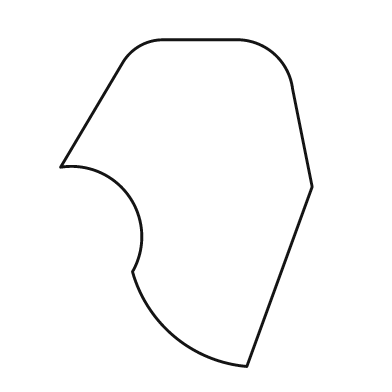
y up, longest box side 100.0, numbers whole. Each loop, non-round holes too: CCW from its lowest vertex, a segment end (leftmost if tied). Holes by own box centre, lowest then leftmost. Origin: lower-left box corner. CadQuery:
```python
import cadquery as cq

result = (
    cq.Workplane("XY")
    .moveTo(57.0, 0.0)
    .lineTo(77.0, 55.0)
    .lineTo(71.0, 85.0)
    .threePointArc((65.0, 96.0), (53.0, 100.0))
    .lineTo(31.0, 100.0)
    .threePointArc((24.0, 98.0), (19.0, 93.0))
    .lineTo(0.0, 61.0)
    .threePointArc((21.0, 52.0), (22.0, 29.0))
    .threePointArc((35.0, 9.0), (57.0, 0.0))
    .close()
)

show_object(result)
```